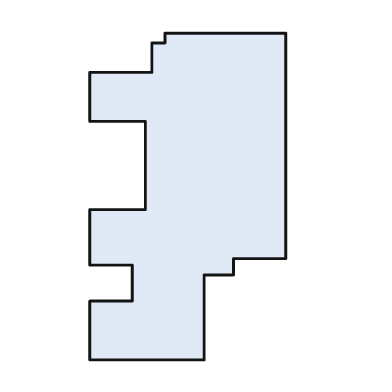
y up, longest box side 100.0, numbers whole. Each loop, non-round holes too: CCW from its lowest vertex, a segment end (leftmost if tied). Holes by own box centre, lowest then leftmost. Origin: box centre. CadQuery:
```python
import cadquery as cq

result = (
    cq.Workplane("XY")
    .moveTo(-30.0, -50.0)
    .lineTo(5.0, -50.0)
    .lineTo(5.0, -24.0)
    .lineTo(14.0, -24.0)
    .lineTo(14.0, -19.0)
    .lineTo(30.0, -19.0)
    .lineTo(30.0, 50.0)
    .lineTo(-7.0, 50.0)
    .lineTo(-7.0, 47.0)
    .lineTo(-11.0, 47.0)
    .lineTo(-11.0, 38.0)
    .lineTo(-30.0, 38.0)
    .lineTo(-30.0, 23.0)
    .lineTo(-13.0, 23.0)
    .lineTo(-13.0, -4.0)
    .lineTo(-30.0, -4.0)
    .lineTo(-30.0, -21.0)
    .lineTo(-17.0, -21.0)
    .lineTo(-17.0, -32.0)
    .lineTo(-30.0, -32.0)
    .close()
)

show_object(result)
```